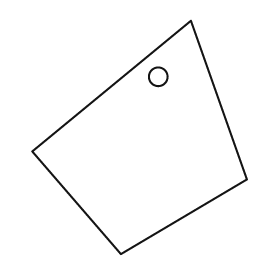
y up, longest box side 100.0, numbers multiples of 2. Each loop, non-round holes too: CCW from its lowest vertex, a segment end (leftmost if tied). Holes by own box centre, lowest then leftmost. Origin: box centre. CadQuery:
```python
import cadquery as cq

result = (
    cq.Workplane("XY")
    .moveTo(-8.0, -50.0)
    .lineTo(46.0, -18.0)
    .lineTo(22.0, 50.0)
    .lineTo(-46.0, -6.0)
    .close()
    .moveTo(8.0, 26.0)
    .circle(4.0)
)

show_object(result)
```